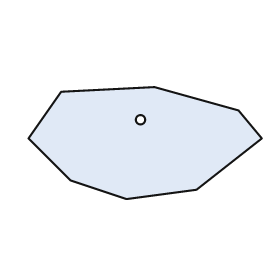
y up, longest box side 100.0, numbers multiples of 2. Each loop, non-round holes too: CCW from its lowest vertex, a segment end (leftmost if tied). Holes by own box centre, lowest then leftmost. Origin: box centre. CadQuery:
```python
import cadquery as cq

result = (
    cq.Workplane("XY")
    .moveTo(-8.0, -24.0)
    .lineTo(22.0, -20.0)
    .lineTo(50.0, 2.0)
    .lineTo(40.0, 14.0)
    .lineTo(4.0, 24.0)
    .lineTo(-36.0, 22.0)
    .lineTo(-50.0, 2.0)
    .lineTo(-32.0, -16.0)
    .close()
    .moveTo(-2.0, 10.0)
    .circle(2.0)
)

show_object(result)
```